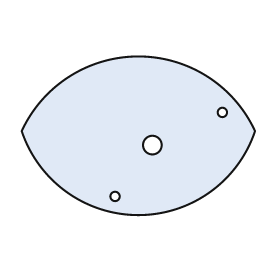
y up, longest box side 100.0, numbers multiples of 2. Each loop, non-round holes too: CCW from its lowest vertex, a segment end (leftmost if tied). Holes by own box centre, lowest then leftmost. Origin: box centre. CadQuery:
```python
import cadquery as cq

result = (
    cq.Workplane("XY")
    .moveTo(-50.0, 2.0)
    .threePointArc((0.0, -34.0), (50.0, 2.0))
    .threePointArc((0.0, 34.0), (-50.0, 2.0))
    .close()
    .moveTo(-10.0, -26.0)
    .circle(2.0)
    .moveTo(6.0, -4.0)
    .circle(4.0)
    .moveTo(36.0, 10.0)
    .circle(2.0)
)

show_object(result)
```